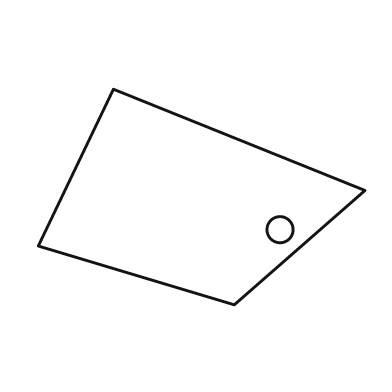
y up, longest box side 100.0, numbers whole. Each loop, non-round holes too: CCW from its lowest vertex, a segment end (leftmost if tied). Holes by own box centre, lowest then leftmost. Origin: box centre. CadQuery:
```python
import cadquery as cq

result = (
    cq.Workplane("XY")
    .moveTo(10.0, -33.0)
    .lineTo(50.0, 2.0)
    .lineTo(-27.0, 33.0)
    .lineTo(-50.0, -15.0)
    .close()
    .moveTo(24.0, -10.0)
    .circle(4.0)
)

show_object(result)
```